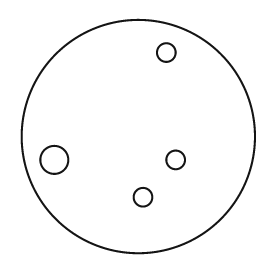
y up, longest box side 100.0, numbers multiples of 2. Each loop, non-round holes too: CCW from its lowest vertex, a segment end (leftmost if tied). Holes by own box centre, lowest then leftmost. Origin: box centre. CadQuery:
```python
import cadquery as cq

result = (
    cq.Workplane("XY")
    .moveTo(0.0, 0.0)
    .circle(50.0)
    .moveTo(2.0, -26.0)
    .circle(4.0)
    .moveTo(-36.0, -10.0)
    .circle(6.0)
    .moveTo(16.0, -10.0)
    .circle(4.0)
    .moveTo(12.0, 36.0)
    .circle(4.0)
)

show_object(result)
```